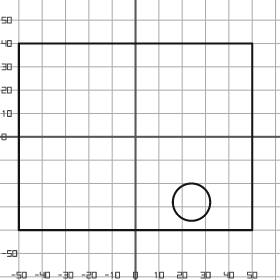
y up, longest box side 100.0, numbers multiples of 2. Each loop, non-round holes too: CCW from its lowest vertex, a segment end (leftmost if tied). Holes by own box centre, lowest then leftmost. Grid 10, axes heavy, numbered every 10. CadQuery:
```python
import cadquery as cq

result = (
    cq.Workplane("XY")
    .moveTo(-50.0, -40.0)
    .lineTo(50.0, -40.0)
    .lineTo(50.0, 40.0)
    .lineTo(-50.0, 40.0)
    .close()
    .moveTo(24.0, -28.0)
    .circle(8.0)
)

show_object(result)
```